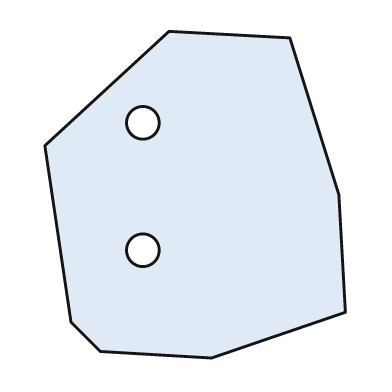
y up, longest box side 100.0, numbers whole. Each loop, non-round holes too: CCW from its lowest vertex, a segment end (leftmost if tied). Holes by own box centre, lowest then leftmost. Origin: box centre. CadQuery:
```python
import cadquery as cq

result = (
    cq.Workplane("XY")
    .moveTo(5.0, -50.0)
    .lineTo(46.0, -36.0)
    .lineTo(44.0, 0.0)
    .lineTo(29.0, 48.0)
    .lineTo(-8.0, 50.0)
    .lineTo(-46.0, 15.0)
    .lineTo(-38.0, -39.0)
    .lineTo(-29.0, -48.0)
    .close()
    .moveTo(-16.0, -17.0)
    .circle(5.0)
    .moveTo(-16.0, 22.0)
    .circle(5.0)
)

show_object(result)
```